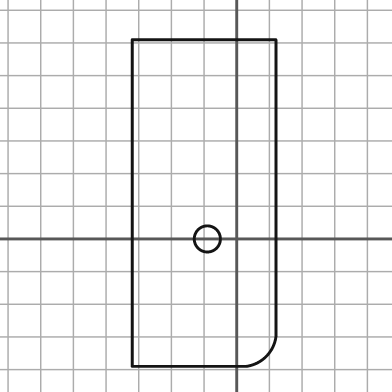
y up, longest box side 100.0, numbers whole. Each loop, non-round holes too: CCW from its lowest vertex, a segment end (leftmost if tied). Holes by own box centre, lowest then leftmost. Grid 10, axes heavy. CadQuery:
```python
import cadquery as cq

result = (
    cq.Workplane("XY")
    .moveTo(-32.0, -39.0)
    .lineTo(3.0, -39.0)
    .threePointArc((9.0, -36.0), (12.0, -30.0))
    .lineTo(12.0, 61.0)
    .lineTo(-32.0, 61.0)
    .close()
    .moveTo(-9.0, 0.0)
    .circle(4.0)
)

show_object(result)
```